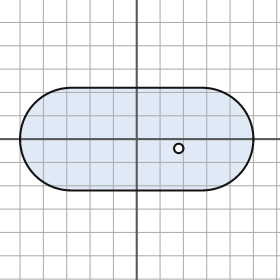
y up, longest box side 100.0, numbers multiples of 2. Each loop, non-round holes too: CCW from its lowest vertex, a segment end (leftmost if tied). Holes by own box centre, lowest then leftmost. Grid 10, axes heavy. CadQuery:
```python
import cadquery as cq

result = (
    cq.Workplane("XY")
    .moveTo(-28.0, -22.0)
    .lineTo(28.0, -22.0)
    .threePointArc((50.0, 0.0), (28.0, 22.0))
    .lineTo(-28.0, 22.0)
    .threePointArc((-50.0, 0.0), (-28.0, -22.0))
    .close()
    .moveTo(18.0, -4.0)
    .circle(2.0)
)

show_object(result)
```